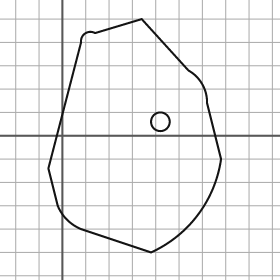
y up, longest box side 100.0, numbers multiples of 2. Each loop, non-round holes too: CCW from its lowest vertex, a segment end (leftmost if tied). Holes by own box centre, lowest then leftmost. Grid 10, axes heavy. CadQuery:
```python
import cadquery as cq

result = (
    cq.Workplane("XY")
    .moveTo(38.0, -50.0)
    .threePointArc((58.0, -34.0), (68.0, -10.0))
    .lineTo(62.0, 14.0)
    .threePointArc((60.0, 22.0), (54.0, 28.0))
    .lineTo(34.0, 50.0)
    .lineTo(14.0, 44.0)
    .threePointArc((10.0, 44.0), (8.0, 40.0))
    .lineTo(-6.0, -14.0)
    .lineTo(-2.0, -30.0)
    .threePointArc((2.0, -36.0), (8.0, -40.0))
    .close()
    .moveTo(42.0, 6.0)
    .circle(4.0)
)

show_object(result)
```